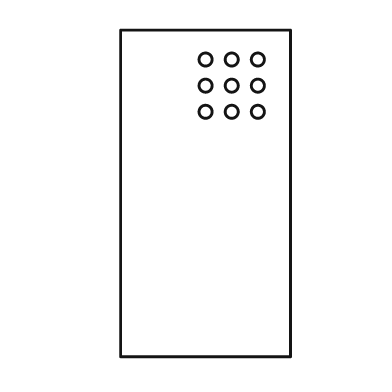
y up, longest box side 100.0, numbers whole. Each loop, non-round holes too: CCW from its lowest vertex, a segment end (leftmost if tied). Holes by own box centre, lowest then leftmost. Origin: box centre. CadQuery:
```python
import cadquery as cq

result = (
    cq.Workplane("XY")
    .moveTo(-26.0, -50.0)
    .lineTo(26.0, -50.0)
    .lineTo(26.0, 50.0)
    .lineTo(-26.0, 50.0)
    .close()
    .moveTo(0.0, 25.0)
    .circle(2.0)
    .moveTo(8.0, 25.0)
    .circle(2.0)
    .moveTo(16.0, 25.0)
    .circle(2.0)
    .moveTo(0.0, 33.0)
    .circle(2.0)
    .moveTo(8.0, 33.0)
    .circle(2.0)
    .moveTo(16.0, 33.0)
    .circle(2.0)
    .moveTo(0.0, 41.0)
    .circle(2.0)
    .moveTo(8.0, 41.0)
    .circle(2.0)
    .moveTo(16.0, 41.0)
    .circle(2.0)
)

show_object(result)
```